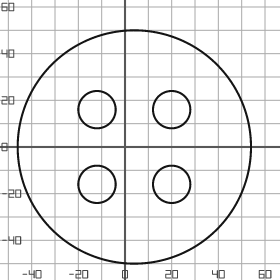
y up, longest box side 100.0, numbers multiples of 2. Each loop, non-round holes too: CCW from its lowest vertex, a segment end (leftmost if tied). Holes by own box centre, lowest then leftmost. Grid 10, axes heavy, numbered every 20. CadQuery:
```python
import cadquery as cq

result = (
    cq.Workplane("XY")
    .moveTo(4.0, 0.0)
    .circle(50.0)
    .moveTo(-12.0, -16.0)
    .circle(8.0)
    .moveTo(20.0, -16.0)
    .circle(8.0)
    .moveTo(-12.0, 16.0)
    .circle(8.0)
    .moveTo(20.0, 16.0)
    .circle(8.0)
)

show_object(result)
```